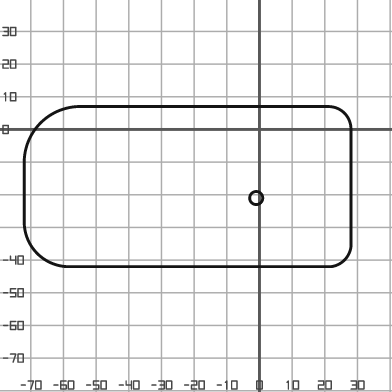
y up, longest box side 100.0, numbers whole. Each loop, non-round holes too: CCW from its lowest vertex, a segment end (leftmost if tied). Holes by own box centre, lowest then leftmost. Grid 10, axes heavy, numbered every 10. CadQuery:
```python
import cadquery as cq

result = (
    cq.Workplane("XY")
    .moveTo(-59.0, -42.0)
    .lineTo(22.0, -42.0)
    .threePointArc((26.0, -40.0), (28.0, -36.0))
    .lineTo(28.0, 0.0)
    .threePointArc((26.0, 5.0), (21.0, 7.0))
    .lineTo(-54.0, 7.0)
    .threePointArc((-67.0, 2.0), (-72.0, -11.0))
    .lineTo(-72.0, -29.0)
    .threePointArc((-68.0, -38.0), (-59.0, -42.0))
    .close()
    .moveTo(-1.0, -21.0)
    .circle(2.0)
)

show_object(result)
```